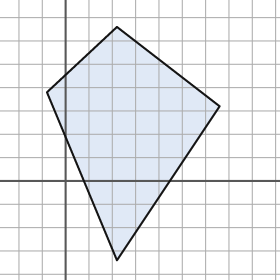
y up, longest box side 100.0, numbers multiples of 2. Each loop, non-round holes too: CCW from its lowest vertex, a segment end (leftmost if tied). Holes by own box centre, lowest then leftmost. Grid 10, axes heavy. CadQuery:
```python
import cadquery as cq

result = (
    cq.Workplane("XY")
    .moveTo(22.0, -34.0)
    .lineTo(66.0, 32.0)
    .lineTo(22.0, 66.0)
    .lineTo(-8.0, 38.0)
    .close()
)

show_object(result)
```